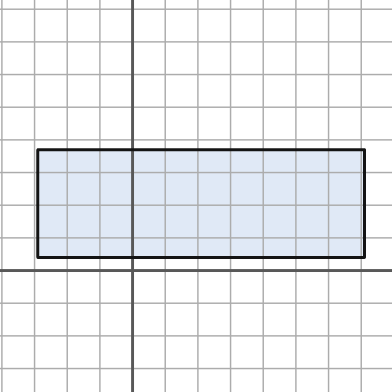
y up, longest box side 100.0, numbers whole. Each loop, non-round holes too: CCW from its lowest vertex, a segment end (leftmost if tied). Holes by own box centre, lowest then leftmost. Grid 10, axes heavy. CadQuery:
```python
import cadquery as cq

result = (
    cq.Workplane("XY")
    .moveTo(-29.0, 4.0)
    .lineTo(71.0, 4.0)
    .lineTo(71.0, 37.0)
    .lineTo(-29.0, 37.0)
    .close()
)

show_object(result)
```